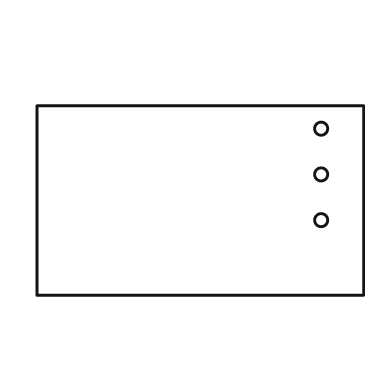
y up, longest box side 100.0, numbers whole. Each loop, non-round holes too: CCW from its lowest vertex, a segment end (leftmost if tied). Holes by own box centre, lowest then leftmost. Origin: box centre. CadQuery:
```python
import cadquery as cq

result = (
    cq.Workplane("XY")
    .moveTo(-50.0, -29.0)
    .lineTo(50.0, -29.0)
    .lineTo(50.0, 29.0)
    .lineTo(-50.0, 29.0)
    .close()
    .moveTo(37.0, -6.0)
    .circle(2.0)
    .moveTo(37.0, 8.0)
    .circle(2.0)
    .moveTo(37.0, 22.0)
    .circle(2.0)
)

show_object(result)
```